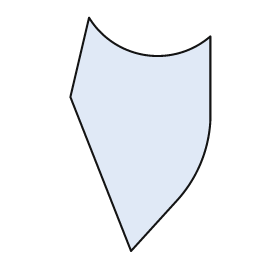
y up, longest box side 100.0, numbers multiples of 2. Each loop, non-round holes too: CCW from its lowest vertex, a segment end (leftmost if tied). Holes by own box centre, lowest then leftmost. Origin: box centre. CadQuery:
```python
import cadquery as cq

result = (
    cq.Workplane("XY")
    .moveTo(-4.0, -50.0)
    .lineTo(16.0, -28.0)
    .threePointArc((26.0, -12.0), (30.0, 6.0))
    .lineTo(30.0, 42.0)
    .threePointArc((2.0, 34.0), (-22.0, 50.0))
    .lineTo(-30.0, 16.0)
    .close()
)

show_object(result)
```